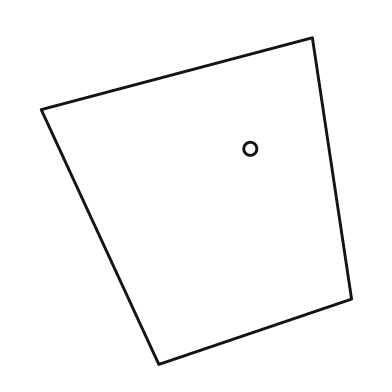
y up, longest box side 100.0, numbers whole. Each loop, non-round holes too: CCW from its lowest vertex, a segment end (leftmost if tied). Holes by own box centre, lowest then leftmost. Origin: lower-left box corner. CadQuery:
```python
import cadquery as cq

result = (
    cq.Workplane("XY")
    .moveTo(36.0, 0.0)
    .lineTo(95.0, 20.0)
    .lineTo(83.0, 100.0)
    .lineTo(0.0, 78.0)
    .close()
    .moveTo(64.0, 66.0)
    .circle(2.0)
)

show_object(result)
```